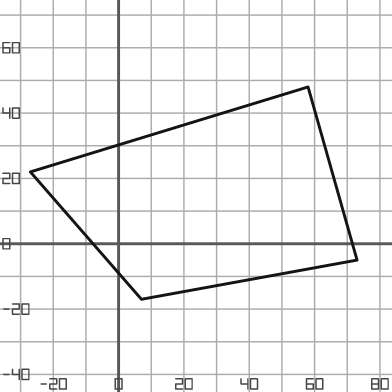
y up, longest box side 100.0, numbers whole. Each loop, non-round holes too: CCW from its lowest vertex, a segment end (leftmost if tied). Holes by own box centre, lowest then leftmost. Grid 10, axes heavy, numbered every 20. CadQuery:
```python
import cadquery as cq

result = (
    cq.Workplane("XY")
    .moveTo(7.0, -17.0)
    .lineTo(73.0, -5.0)
    .lineTo(58.0, 48.0)
    .lineTo(-27.0, 22.0)
    .close()
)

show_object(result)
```